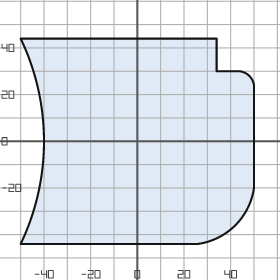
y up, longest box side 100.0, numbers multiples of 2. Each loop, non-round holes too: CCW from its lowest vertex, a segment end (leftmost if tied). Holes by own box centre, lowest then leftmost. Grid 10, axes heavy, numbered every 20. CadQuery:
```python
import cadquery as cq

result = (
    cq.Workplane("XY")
    .moveTo(-50.0, -44.0)
    .lineTo(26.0, -44.0)
    .threePointArc((42.0, -36.0), (50.0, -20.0))
    .lineTo(50.0, 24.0)
    .threePointArc((48.0, 28.0), (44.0, 30.0))
    .lineTo(34.0, 30.0)
    .lineTo(34.0, 44.0)
    .lineTo(-50.0, 44.0)
    .threePointArc((-40.0, 0.0), (-50.0, -44.0))
    .close()
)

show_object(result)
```